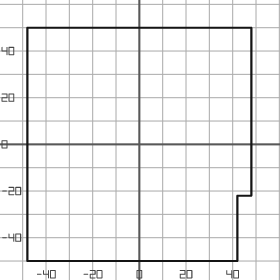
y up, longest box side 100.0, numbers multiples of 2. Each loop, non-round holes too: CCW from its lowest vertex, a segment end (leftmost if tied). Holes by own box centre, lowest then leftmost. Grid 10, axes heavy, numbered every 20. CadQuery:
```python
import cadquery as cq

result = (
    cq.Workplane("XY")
    .moveTo(-48.0, -50.0)
    .lineTo(42.0, -50.0)
    .lineTo(42.0, -22.0)
    .lineTo(48.0, -22.0)
    .lineTo(48.0, 50.0)
    .lineTo(-48.0, 50.0)
    .close()
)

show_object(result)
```